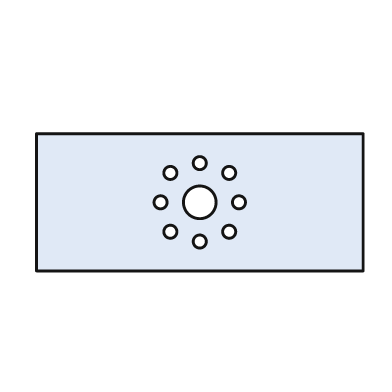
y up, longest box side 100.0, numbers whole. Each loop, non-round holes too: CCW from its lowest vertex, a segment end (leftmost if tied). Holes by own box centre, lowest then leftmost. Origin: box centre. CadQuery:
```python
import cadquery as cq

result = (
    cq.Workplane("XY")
    .moveTo(-50.0, -21.0)
    .lineTo(50.0, -21.0)
    .lineTo(50.0, 21.0)
    .lineTo(-50.0, 21.0)
    .close()
    .moveTo(0.0, -12.0)
    .circle(2.0)
    .moveTo(-9.0, -9.0)
    .circle(2.0)
    .moveTo(9.0, -9.0)
    .circle(2.0)
    .moveTo(-12.0, 0.0)
    .circle(2.0)
    .moveTo(0.0, 0.0)
    .circle(5.0)
    .moveTo(12.0, 0.0)
    .circle(2.0)
    .moveTo(-9.0, 9.0)
    .circle(2.0)
    .moveTo(9.0, 9.0)
    .circle(2.0)
    .moveTo(0.0, 12.0)
    .circle(2.0)
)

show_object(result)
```